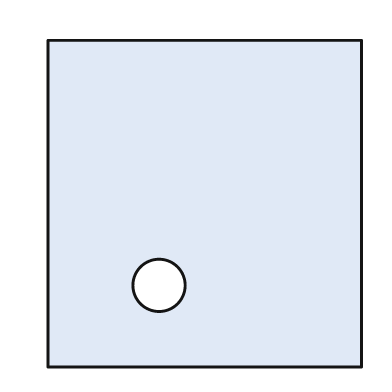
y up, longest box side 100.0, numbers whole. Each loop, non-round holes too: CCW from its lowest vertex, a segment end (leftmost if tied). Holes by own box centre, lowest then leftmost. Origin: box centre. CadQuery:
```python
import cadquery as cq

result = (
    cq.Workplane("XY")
    .moveTo(-48.0, -50.0)
    .lineTo(48.0, -50.0)
    .lineTo(48.0, 50.0)
    .lineTo(-48.0, 50.0)
    .close()
    .moveTo(-14.0, -25.0)
    .circle(8.0)
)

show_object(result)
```